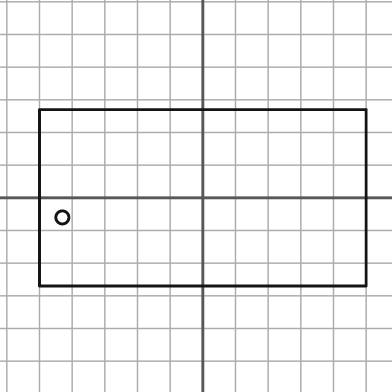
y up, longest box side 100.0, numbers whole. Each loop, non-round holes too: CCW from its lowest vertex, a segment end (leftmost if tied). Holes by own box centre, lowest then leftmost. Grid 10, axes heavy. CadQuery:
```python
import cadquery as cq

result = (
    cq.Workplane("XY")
    .moveTo(-50.0, -27.0)
    .lineTo(50.0, -27.0)
    .lineTo(50.0, 27.0)
    .lineTo(-50.0, 27.0)
    .close()
    .moveTo(-43.0, -6.0)
    .circle(2.0)
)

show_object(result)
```